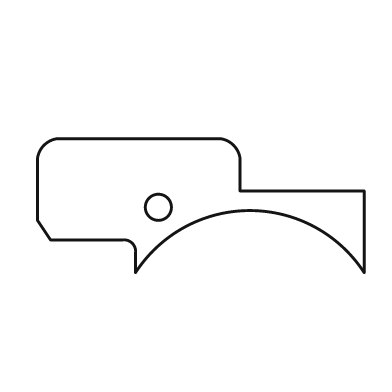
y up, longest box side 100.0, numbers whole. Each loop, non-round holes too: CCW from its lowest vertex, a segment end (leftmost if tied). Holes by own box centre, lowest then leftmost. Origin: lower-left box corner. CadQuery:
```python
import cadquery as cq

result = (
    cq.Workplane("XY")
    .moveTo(30.0, 0.0)
    .threePointArc((65.0, 19.0), (100.0, 0.0))
    .lineTo(100.0, 25.0)
    .lineTo(62.0, 25.0)
    .lineTo(62.0, 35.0)
    .threePointArc((60.0, 39.0), (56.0, 41.0))
    .lineTo(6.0, 41.0)
    .threePointArc((2.0, 39.0), (0.0, 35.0))
    .lineTo(0.0, 16.0)
    .lineTo(4.0, 10.0)
    .lineTo(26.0, 10.0)
    .threePointArc((29.0, 9.0), (30.0, 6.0))
    .close()
    .moveTo(37.0, 20.0)
    .circle(4.0)
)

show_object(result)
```